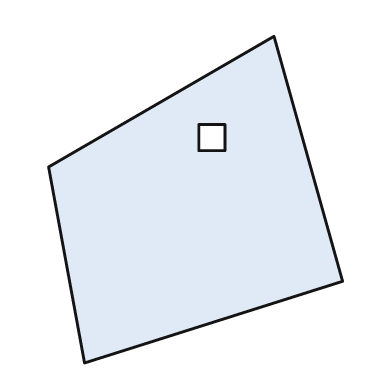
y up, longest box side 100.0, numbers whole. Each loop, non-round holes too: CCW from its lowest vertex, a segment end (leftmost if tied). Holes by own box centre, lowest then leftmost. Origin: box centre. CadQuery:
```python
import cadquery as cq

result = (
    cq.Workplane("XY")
    .moveTo(-34.0, -50.0)
    .lineTo(45.0, -25.0)
    .lineTo(24.0, 50.0)
    .lineTo(-45.0, 10.0)
    .close()
    .moveTo(1.0, 15.0)
    .lineTo(9.0, 15.0)
    .lineTo(9.0, 23.0)
    .lineTo(1.0, 23.0)
    .close()
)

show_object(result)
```